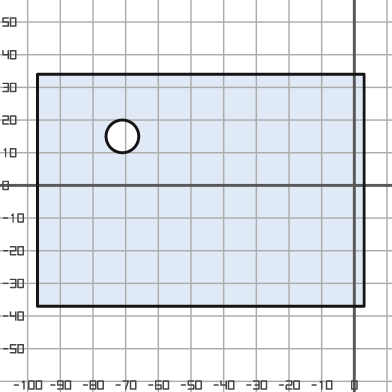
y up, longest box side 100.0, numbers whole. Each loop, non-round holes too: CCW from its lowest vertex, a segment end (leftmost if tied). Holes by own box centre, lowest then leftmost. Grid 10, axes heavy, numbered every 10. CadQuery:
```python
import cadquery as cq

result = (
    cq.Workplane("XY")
    .moveTo(-97.0, -37.0)
    .lineTo(3.0, -37.0)
    .lineTo(3.0, 34.0)
    .lineTo(-97.0, 34.0)
    .close()
    .moveTo(-71.0, 15.0)
    .circle(5.0)
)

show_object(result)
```